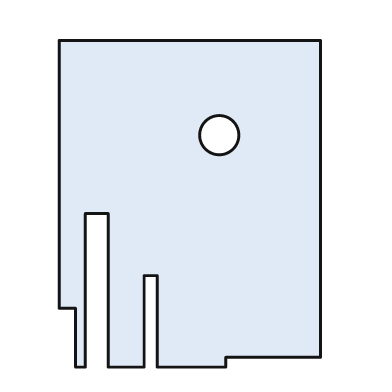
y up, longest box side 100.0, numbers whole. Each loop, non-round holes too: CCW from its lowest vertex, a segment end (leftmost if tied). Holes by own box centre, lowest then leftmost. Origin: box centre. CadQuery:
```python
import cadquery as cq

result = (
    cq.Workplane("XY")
    .moveTo(-35.0, -50.0)
    .lineTo(-32.0, -50.0)
    .lineTo(-32.0, -3.0)
    .lineTo(-25.0, -3.0)
    .lineTo(-25.0, -50.0)
    .lineTo(-14.0, -50.0)
    .lineTo(-14.0, -22.0)
    .lineTo(-10.0, -22.0)
    .lineTo(-10.0, -50.0)
    .lineTo(11.0, -50.0)
    .lineTo(11.0, -47.0)
    .lineTo(40.0, -47.0)
    .lineTo(40.0, 50.0)
    .lineTo(-40.0, 50.0)
    .lineTo(-40.0, -32.0)
    .lineTo(-35.0, -32.0)
    .close()
    .moveTo(9.0, 21.0)
    .circle(6.0)
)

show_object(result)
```